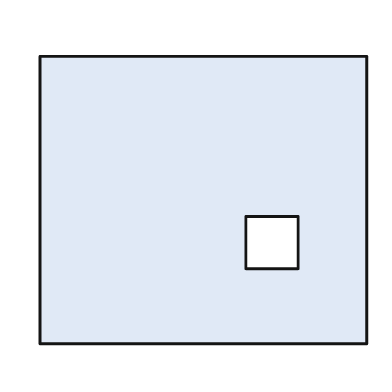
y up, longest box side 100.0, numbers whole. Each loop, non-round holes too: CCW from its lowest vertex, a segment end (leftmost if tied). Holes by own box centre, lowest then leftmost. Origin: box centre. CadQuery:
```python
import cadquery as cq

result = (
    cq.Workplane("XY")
    .moveTo(-50.0, -44.0)
    .lineTo(50.0, -44.0)
    .lineTo(50.0, 44.0)
    .lineTo(-50.0, 44.0)
    .close()
    .moveTo(13.0, -21.0)
    .lineTo(29.0, -21.0)
    .lineTo(29.0, -5.0)
    .lineTo(13.0, -5.0)
    .close()
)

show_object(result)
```